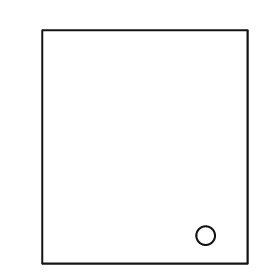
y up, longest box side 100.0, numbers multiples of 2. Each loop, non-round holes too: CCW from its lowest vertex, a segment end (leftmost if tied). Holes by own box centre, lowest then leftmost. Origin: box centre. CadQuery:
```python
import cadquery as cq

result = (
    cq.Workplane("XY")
    .moveTo(-44.0, -50.0)
    .lineTo(44.0, -50.0)
    .lineTo(44.0, 50.0)
    .lineTo(-44.0, 50.0)
    .close()
    .moveTo(26.0, -38.0)
    .circle(4.0)
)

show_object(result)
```